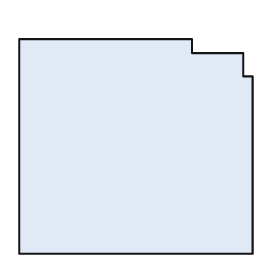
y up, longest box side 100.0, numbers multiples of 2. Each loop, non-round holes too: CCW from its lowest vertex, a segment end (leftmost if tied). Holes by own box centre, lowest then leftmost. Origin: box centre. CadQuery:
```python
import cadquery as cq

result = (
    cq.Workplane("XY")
    .moveTo(-50.0, -46.0)
    .lineTo(50.0, -46.0)
    .lineTo(50.0, 30.0)
    .lineTo(46.0, 30.0)
    .lineTo(46.0, 40.0)
    .lineTo(24.0, 40.0)
    .lineTo(24.0, 46.0)
    .lineTo(-50.0, 46.0)
    .close()
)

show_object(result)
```